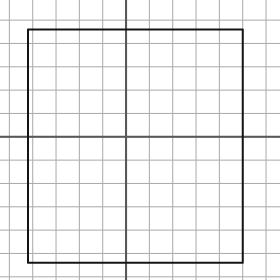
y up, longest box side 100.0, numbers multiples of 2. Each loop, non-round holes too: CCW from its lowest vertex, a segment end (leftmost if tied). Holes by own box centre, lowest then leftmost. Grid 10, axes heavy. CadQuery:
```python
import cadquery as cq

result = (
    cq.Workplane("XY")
    .moveTo(-42.0, -54.0)
    .lineTo(50.0, -54.0)
    .lineTo(50.0, 46.0)
    .lineTo(-42.0, 46.0)
    .close()
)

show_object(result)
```